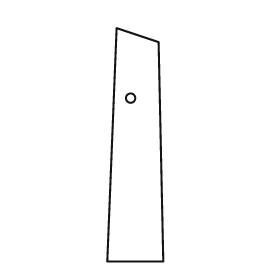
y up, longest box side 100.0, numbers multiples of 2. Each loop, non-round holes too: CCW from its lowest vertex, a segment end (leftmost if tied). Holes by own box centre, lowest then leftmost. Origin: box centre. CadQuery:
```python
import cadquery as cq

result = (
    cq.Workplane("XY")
    .moveTo(-12.0, -50.0)
    .lineTo(12.0, -50.0)
    .lineTo(10.0, 44.0)
    .lineTo(-8.0, 50.0)
    .close()
    .moveTo(-2.0, 20.0)
    .circle(2.0)
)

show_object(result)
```